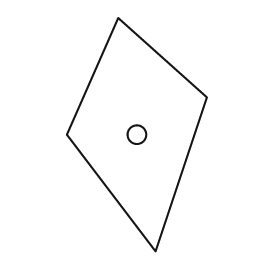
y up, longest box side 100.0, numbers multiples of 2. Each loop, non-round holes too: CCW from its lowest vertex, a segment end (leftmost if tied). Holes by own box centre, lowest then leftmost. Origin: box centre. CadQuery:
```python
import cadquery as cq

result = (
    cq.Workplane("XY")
    .moveTo(8.0, -50.0)
    .lineTo(30.0, 16.0)
    .lineTo(-8.0, 50.0)
    .lineTo(-30.0, 0.0)
    .close()
    .moveTo(0.0, 0.0)
    .circle(4.0)
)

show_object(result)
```